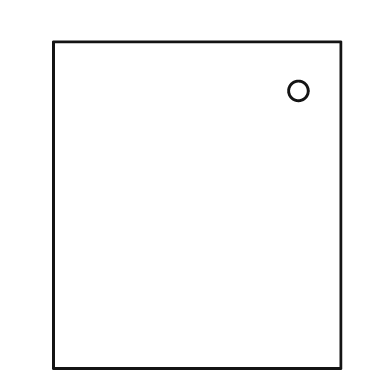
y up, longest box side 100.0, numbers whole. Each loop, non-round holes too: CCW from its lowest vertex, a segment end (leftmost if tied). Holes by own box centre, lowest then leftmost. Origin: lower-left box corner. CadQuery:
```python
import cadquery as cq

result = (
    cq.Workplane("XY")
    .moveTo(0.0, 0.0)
    .lineTo(88.0, 0.0)
    .lineTo(88.0, 100.0)
    .lineTo(0.0, 100.0)
    .close()
    .moveTo(75.0, 85.0)
    .circle(3.0)
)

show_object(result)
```